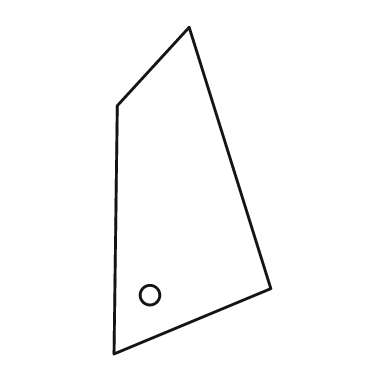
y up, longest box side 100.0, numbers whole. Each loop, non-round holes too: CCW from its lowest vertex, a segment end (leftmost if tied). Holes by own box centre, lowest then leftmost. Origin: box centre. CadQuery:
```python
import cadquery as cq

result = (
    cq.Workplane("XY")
    .moveTo(-24.0, -50.0)
    .lineTo(24.0, -30.0)
    .lineTo(-1.0, 50.0)
    .lineTo(-23.0, 26.0)
    .close()
    .moveTo(-13.0, -32.0)
    .circle(3.0)
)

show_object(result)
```